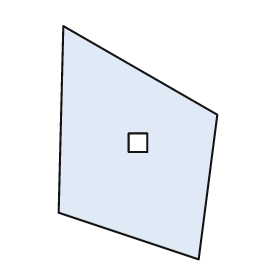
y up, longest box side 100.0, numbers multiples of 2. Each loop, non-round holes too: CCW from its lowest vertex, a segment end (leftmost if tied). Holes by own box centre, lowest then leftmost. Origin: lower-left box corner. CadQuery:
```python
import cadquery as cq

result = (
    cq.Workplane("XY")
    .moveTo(60.0, 0.0)
    .lineTo(68.0, 62.0)
    .lineTo(2.0, 100.0)
    .lineTo(0.0, 20.0)
    .close()
    .moveTo(30.0, 46.0)
    .lineTo(38.0, 46.0)
    .lineTo(38.0, 54.0)
    .lineTo(30.0, 54.0)
    .close()
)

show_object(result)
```